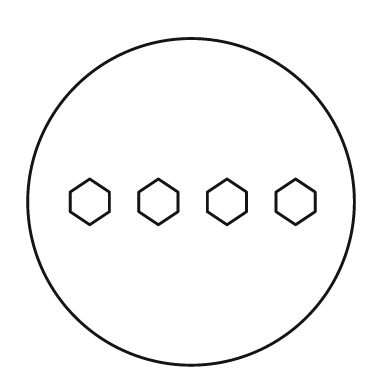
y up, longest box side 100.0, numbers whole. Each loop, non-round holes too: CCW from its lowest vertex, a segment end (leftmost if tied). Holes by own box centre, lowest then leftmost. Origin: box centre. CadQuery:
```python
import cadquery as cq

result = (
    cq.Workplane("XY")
    .moveTo(0.0, 0.0)
    .circle(50.0)
    .moveTo(-31.0, -7.0)
    .lineTo(-25.0, -3.0)
    .lineTo(-25.0, 3.0)
    .lineTo(-31.0, 7.0)
    .lineTo(-37.0, 3.0)
    .lineTo(-37.0, -3.0)
    .close()
    .moveTo(-10.0, -7.0)
    .lineTo(-4.0, -3.0)
    .lineTo(-4.0, 3.0)
    .lineTo(-10.0, 7.0)
    .lineTo(-16.0, 3.0)
    .lineTo(-16.0, -3.0)
    .close()
    .moveTo(11.0, -7.0)
    .lineTo(17.0, -3.0)
    .lineTo(17.0, 3.0)
    .lineTo(11.0, 7.0)
    .lineTo(5.0, 3.0)
    .lineTo(5.0, -3.0)
    .close()
    .moveTo(32.0, -7.0)
    .lineTo(38.0, -3.0)
    .lineTo(38.0, 3.0)
    .lineTo(32.0, 7.0)
    .lineTo(26.0, 3.0)
    .lineTo(26.0, -3.0)
    .close()
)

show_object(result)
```